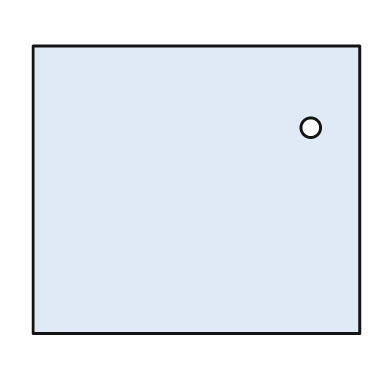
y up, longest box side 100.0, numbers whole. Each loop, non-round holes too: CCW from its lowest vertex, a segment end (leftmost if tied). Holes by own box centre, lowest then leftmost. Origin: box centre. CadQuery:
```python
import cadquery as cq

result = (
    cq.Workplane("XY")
    .moveTo(-50.0, -44.0)
    .lineTo(50.0, -44.0)
    .lineTo(50.0, 44.0)
    .lineTo(-50.0, 44.0)
    .close()
    .moveTo(35.0, 19.0)
    .circle(3.0)
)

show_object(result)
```